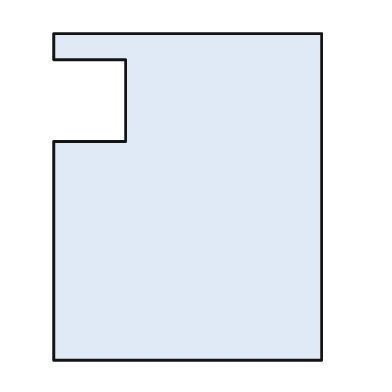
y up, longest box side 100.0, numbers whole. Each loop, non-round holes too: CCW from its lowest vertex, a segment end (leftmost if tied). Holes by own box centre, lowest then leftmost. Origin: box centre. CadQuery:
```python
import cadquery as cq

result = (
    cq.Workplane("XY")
    .moveTo(-41.0, -50.0)
    .lineTo(41.0, -50.0)
    .lineTo(41.0, 50.0)
    .lineTo(-41.0, 50.0)
    .lineTo(-41.0, 42.0)
    .lineTo(-19.0, 42.0)
    .lineTo(-19.0, 17.0)
    .lineTo(-41.0, 17.0)
    .close()
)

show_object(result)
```